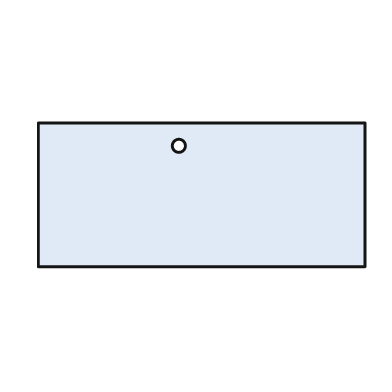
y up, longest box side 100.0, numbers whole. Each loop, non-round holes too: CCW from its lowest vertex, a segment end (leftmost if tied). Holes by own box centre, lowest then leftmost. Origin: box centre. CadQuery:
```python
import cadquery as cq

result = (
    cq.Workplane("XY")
    .moveTo(-50.0, -22.0)
    .lineTo(50.0, -22.0)
    .lineTo(50.0, 22.0)
    .lineTo(-50.0, 22.0)
    .close()
    .moveTo(-7.0, 15.0)
    .circle(2.0)
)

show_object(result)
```